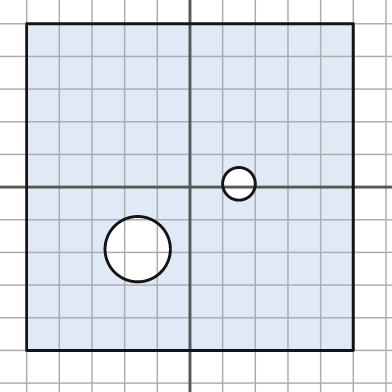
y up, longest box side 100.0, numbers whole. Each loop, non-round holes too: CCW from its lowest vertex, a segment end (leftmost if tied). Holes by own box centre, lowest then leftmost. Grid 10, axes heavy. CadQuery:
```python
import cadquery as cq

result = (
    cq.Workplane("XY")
    .moveTo(-50.0, -50.0)
    .lineTo(50.0, -50.0)
    .lineTo(50.0, 50.0)
    .lineTo(-50.0, 50.0)
    .close()
    .moveTo(-16.0, -19.0)
    .circle(10.0)
    .moveTo(15.0, 1.0)
    .circle(5.0)
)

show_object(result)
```